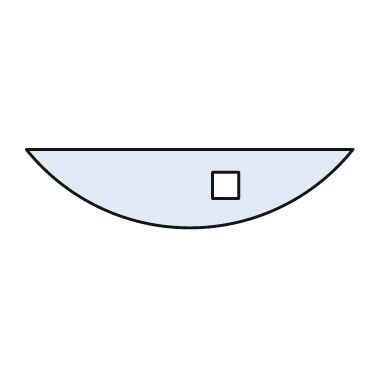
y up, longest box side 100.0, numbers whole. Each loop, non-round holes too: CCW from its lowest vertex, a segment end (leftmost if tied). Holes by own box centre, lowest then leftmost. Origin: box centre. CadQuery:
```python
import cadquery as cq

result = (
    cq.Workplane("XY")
    .moveTo(-50.0, 12.0)
    .threePointArc((0.0, -12.0), (50.0, 12.0))
    .close()
    .moveTo(7.0, -3.0)
    .lineTo(15.0, -3.0)
    .lineTo(15.0, 5.0)
    .lineTo(7.0, 5.0)
    .close()
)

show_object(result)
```